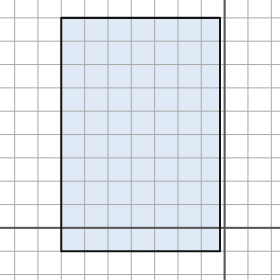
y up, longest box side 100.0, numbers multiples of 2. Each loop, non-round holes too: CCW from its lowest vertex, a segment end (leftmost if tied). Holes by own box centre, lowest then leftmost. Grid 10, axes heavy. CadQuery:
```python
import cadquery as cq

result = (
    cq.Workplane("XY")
    .moveTo(-70.0, -10.0)
    .lineTo(-2.0, -10.0)
    .lineTo(-2.0, 90.0)
    .lineTo(-70.0, 90.0)
    .close()
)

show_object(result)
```